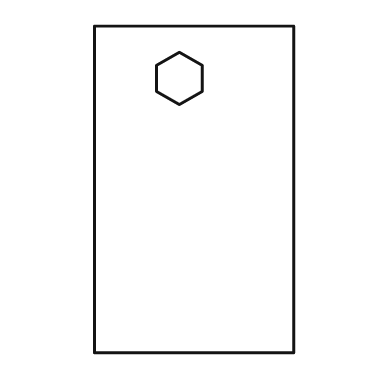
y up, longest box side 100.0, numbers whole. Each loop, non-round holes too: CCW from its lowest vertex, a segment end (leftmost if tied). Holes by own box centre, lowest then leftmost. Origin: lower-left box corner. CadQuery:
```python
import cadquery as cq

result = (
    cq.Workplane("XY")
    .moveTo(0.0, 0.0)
    .lineTo(61.0, 0.0)
    .lineTo(61.0, 100.0)
    .lineTo(0.0, 100.0)
    .close()
    .moveTo(26.0, 76.0)
    .lineTo(33.0, 80.0)
    .lineTo(33.0, 88.0)
    .lineTo(26.0, 92.0)
    .lineTo(19.0, 88.0)
    .lineTo(19.0, 80.0)
    .close()
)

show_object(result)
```